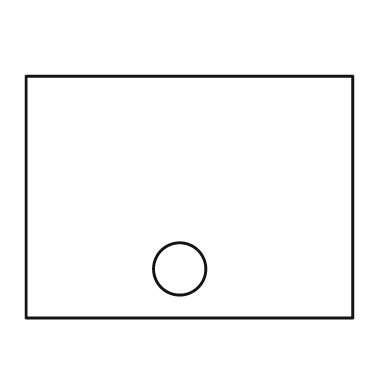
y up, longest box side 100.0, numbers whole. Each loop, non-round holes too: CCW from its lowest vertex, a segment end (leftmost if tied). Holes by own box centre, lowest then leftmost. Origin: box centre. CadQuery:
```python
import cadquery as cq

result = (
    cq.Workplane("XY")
    .moveTo(-50.0, -37.0)
    .lineTo(50.0, -37.0)
    .lineTo(50.0, 37.0)
    .lineTo(-50.0, 37.0)
    .close()
    .moveTo(-3.0, -22.0)
    .circle(8.0)
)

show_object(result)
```